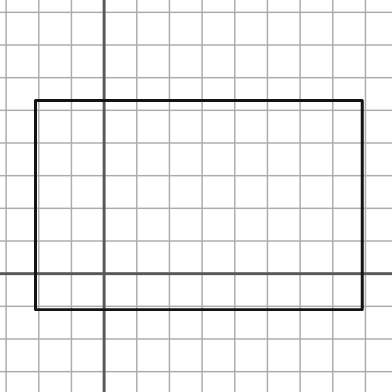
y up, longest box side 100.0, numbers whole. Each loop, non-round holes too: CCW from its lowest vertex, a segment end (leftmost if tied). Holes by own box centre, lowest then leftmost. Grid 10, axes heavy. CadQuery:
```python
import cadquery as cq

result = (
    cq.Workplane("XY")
    .moveTo(-21.0, -11.0)
    .lineTo(79.0, -11.0)
    .lineTo(79.0, 53.0)
    .lineTo(-21.0, 53.0)
    .close()
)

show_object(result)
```